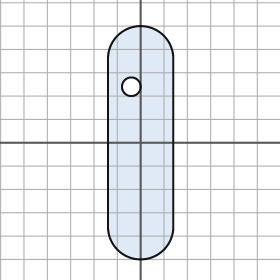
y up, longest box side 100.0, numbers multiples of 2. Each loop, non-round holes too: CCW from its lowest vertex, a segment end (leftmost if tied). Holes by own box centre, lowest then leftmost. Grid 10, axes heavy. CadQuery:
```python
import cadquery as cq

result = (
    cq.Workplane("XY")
    .moveTo(-14.0, -36.0)
    .threePointArc((0.0, -50.0), (14.0, -36.0))
    .lineTo(14.0, 36.0)
    .threePointArc((0.0, 50.0), (-14.0, 36.0))
    .close()
    .moveTo(-4.0, 24.0)
    .circle(4.0)
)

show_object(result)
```